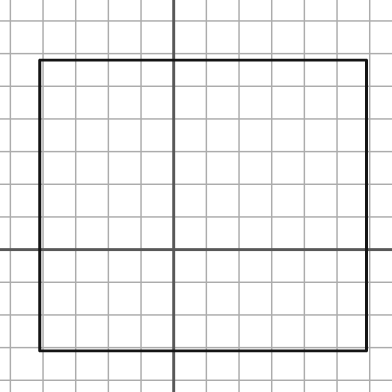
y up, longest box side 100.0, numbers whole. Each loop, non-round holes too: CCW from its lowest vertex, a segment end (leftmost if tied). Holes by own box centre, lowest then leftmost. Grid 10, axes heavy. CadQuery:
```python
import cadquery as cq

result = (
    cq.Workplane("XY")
    .moveTo(-41.0, -31.0)
    .lineTo(59.0, -31.0)
    .lineTo(59.0, 58.0)
    .lineTo(-41.0, 58.0)
    .close()
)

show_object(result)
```